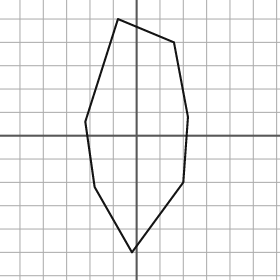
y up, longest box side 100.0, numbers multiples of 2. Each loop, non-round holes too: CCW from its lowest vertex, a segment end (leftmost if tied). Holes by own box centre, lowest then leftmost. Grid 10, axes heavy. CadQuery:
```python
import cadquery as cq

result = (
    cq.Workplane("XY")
    .moveTo(-2.0, -50.0)
    .lineTo(20.0, -20.0)
    .lineTo(22.0, 8.0)
    .lineTo(16.0, 40.0)
    .lineTo(-8.0, 50.0)
    .lineTo(-22.0, 6.0)
    .lineTo(-18.0, -22.0)
    .close()
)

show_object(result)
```